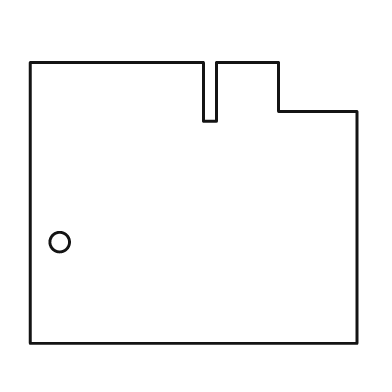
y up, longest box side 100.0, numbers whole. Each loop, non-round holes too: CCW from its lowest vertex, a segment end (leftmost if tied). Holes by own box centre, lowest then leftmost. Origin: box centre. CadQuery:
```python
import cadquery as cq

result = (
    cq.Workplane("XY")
    .moveTo(-50.0, -43.0)
    .lineTo(50.0, -43.0)
    .lineTo(50.0, 28.0)
    .lineTo(26.0, 28.0)
    .lineTo(26.0, 43.0)
    .lineTo(7.0, 43.0)
    .lineTo(7.0, 25.0)
    .lineTo(3.0, 25.0)
    .lineTo(3.0, 43.0)
    .lineTo(-50.0, 43.0)
    .close()
    .moveTo(-41.0, -12.0)
    .circle(3.0)
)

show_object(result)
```